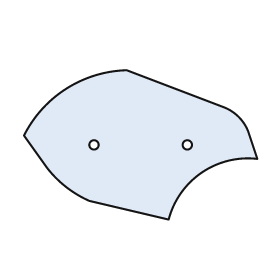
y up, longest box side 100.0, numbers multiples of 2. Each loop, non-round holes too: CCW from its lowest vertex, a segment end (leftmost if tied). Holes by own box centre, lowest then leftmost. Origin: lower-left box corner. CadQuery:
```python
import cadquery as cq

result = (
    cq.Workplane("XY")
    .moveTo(62.0, 0.0)
    .threePointArc((76.0, 20.0), (100.0, 26.0))
    .lineTo(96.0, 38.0)
    .threePointArc((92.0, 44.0), (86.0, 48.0))
    .lineTo(44.0, 64.0)
    .threePointArc((18.0, 56.0), (0.0, 36.0))
    .lineTo(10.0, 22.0)
    .threePointArc((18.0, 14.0), (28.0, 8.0))
    .close()
    .moveTo(30.0, 32.0)
    .circle(2.0)
    .moveTo(70.0, 32.0)
    .circle(2.0)
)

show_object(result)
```